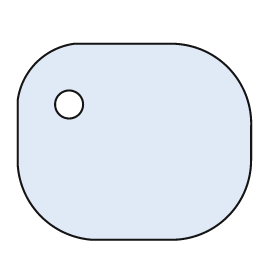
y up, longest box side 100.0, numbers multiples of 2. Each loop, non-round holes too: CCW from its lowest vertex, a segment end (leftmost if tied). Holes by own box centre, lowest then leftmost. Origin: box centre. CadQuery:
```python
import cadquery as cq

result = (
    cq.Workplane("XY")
    .moveTo(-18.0, -42.0)
    .lineTo(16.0, -42.0)
    .threePointArc((40.0, -32.0), (50.0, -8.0))
    .lineTo(50.0, 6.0)
    .threePointArc((40.0, 32.0), (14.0, 42.0))
    .lineTo(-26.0, 42.0)
    .threePointArc((-42.0, 34.0), (-50.0, 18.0))
    .lineTo(-50.0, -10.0)
    .threePointArc((-40.0, -32.0), (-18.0, -42.0))
    .close()
    .moveTo(-28.0, 16.0)
    .circle(6.0)
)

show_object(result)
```